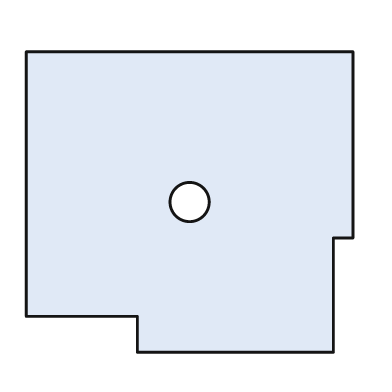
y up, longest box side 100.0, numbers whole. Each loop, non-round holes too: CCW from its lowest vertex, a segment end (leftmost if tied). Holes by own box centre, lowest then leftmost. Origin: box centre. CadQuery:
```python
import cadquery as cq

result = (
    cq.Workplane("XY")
    .moveTo(-16.0, -46.0)
    .lineTo(44.0, -46.0)
    .lineTo(44.0, -11.0)
    .lineTo(50.0, -11.0)
    .lineTo(50.0, 46.0)
    .lineTo(-50.0, 46.0)
    .lineTo(-50.0, -35.0)
    .lineTo(-16.0, -35.0)
    .close()
    .moveTo(0.0, 0.0)
    .circle(6.0)
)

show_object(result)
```